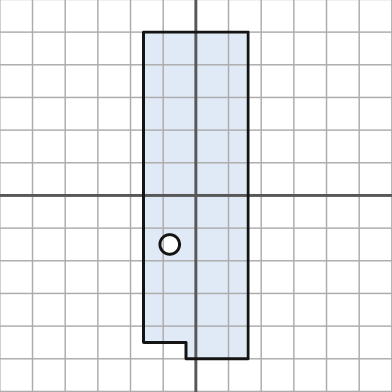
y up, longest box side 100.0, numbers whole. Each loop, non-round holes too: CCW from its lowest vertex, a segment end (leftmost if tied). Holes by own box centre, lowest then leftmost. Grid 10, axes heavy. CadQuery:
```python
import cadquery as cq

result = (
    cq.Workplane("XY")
    .moveTo(-3.0, -50.0)
    .lineTo(16.0, -50.0)
    .lineTo(16.0, 50.0)
    .lineTo(-16.0, 50.0)
    .lineTo(-16.0, -45.0)
    .lineTo(-3.0, -45.0)
    .close()
    .moveTo(-8.0, -15.0)
    .circle(3.0)
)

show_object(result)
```